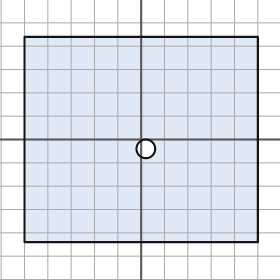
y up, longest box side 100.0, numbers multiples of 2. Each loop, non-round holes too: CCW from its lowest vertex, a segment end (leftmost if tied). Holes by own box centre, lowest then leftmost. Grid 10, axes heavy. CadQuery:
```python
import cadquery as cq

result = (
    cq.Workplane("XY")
    .moveTo(-50.0, -44.0)
    .lineTo(50.0, -44.0)
    .lineTo(50.0, 44.0)
    .lineTo(-50.0, 44.0)
    .close()
    .moveTo(2.0, -4.0)
    .circle(4.0)
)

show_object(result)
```